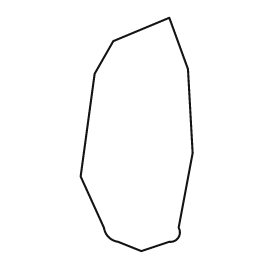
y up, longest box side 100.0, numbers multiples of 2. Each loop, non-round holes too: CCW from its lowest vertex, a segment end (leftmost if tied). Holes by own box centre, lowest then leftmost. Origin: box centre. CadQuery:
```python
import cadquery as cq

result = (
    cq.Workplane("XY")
    .moveTo(2.0, -50.0)
    .lineTo(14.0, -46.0)
    .threePointArc((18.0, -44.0), (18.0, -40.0))
    .lineTo(24.0, -8.0)
    .lineTo(22.0, 28.0)
    .lineTo(14.0, 50.0)
    .lineTo(-10.0, 40.0)
    .lineTo(-18.0, 26.0)
    .lineTo(-24.0, -18.0)
    .lineTo(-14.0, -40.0)
    .threePointArc((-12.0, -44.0), (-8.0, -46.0))
    .close()
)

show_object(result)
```